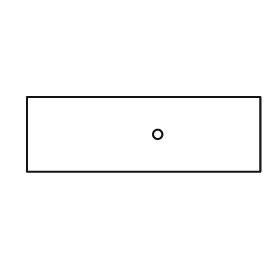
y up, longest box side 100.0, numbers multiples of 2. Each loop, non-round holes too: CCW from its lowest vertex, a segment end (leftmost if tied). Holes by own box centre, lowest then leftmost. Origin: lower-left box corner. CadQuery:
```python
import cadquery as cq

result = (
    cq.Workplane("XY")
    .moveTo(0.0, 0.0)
    .lineTo(100.0, 0.0)
    .lineTo(100.0, 32.0)
    .lineTo(0.0, 32.0)
    .close()
    .moveTo(56.0, 16.0)
    .circle(2.0)
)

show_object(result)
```